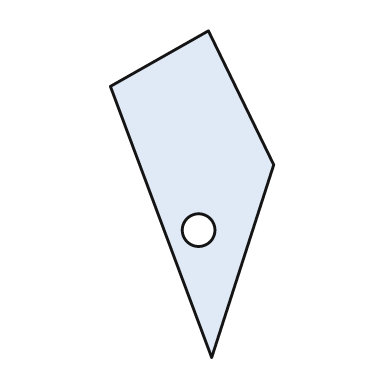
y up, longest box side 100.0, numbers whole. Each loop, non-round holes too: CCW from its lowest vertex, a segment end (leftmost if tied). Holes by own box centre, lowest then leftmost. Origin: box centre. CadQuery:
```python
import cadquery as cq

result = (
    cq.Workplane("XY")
    .moveTo(6.0, -50.0)
    .lineTo(25.0, 9.0)
    .lineTo(5.0, 50.0)
    .lineTo(-25.0, 33.0)
    .close()
    .moveTo(2.0, -11.0)
    .circle(5.0)
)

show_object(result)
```